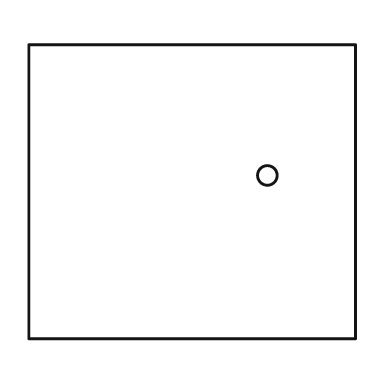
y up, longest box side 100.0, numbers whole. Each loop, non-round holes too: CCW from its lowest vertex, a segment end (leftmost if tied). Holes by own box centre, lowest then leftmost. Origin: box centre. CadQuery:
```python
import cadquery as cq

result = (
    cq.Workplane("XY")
    .moveTo(-50.0, -45.0)
    .lineTo(50.0, -45.0)
    .lineTo(50.0, 45.0)
    .lineTo(-50.0, 45.0)
    .close()
    .moveTo(23.0, 5.0)
    .circle(3.0)
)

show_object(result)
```